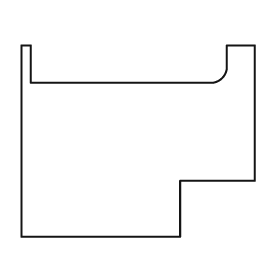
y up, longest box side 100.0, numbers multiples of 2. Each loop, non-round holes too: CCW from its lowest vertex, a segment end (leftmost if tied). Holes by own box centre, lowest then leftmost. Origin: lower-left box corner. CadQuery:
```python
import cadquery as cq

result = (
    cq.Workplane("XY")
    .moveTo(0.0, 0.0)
    .lineTo(68.0, 0.0)
    .lineTo(68.0, 24.0)
    .lineTo(100.0, 24.0)
    .lineTo(100.0, 82.0)
    .lineTo(88.0, 82.0)
    .lineTo(88.0, 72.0)
    .threePointArc((86.0, 68.0), (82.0, 66.0))
    .lineTo(4.0, 66.0)
    .lineTo(4.0, 82.0)
    .lineTo(0.0, 82.0)
    .close()
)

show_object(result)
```